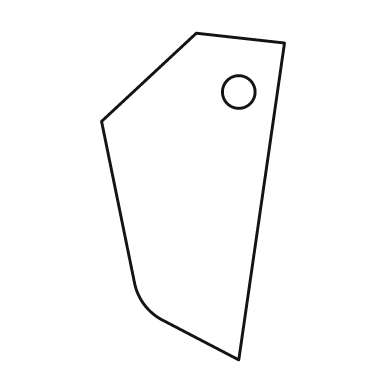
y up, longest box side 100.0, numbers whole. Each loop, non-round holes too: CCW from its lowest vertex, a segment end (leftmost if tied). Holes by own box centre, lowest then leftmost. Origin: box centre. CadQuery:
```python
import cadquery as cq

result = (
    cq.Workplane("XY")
    .moveTo(14.0, -50.0)
    .lineTo(28.0, 47.0)
    .lineTo(1.0, 50.0)
    .lineTo(-28.0, 23.0)
    .lineTo(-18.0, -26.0)
    .threePointArc((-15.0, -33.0), (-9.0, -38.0))
    .close()
    .moveTo(14.0, 32.0)
    .circle(5.0)
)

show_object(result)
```